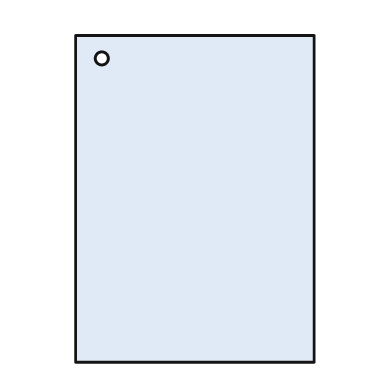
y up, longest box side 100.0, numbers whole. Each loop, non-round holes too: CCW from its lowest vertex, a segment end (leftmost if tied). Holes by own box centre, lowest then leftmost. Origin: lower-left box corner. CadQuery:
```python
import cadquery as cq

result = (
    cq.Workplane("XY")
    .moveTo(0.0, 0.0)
    .lineTo(73.0, 0.0)
    .lineTo(73.0, 100.0)
    .lineTo(0.0, 100.0)
    .close()
    .moveTo(8.0, 93.0)
    .circle(2.0)
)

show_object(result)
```